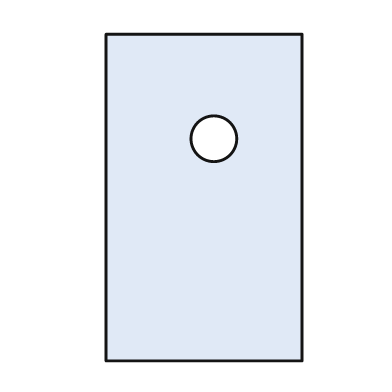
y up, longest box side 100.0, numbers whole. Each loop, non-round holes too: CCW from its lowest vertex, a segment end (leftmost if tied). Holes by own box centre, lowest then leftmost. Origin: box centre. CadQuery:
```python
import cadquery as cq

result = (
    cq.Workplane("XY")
    .moveTo(-30.0, -50.0)
    .lineTo(30.0, -50.0)
    .lineTo(30.0, 50.0)
    .lineTo(-30.0, 50.0)
    .close()
    .moveTo(3.0, 18.0)
    .circle(7.0)
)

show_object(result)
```